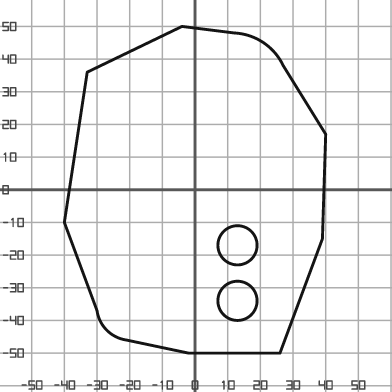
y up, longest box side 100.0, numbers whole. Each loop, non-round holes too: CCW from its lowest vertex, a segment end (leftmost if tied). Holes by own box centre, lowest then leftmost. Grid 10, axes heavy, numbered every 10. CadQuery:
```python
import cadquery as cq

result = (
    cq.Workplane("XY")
    .moveTo(-2.0, -50.0)
    .lineTo(26.0, -50.0)
    .lineTo(39.0, -15.0)
    .lineTo(40.0, 17.0)
    .lineTo(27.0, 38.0)
    .threePointArc((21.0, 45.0), (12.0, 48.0))
    .lineTo(-4.0, 50.0)
    .lineTo(-33.0, 36.0)
    .lineTo(-40.0, -10.0)
    .lineTo(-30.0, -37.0)
    .threePointArc((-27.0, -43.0), (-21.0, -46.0))
    .close()
    .moveTo(13.0, -34.0)
    .circle(6.0)
    .moveTo(13.0, -17.0)
    .circle(6.0)
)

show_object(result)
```